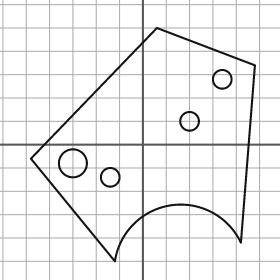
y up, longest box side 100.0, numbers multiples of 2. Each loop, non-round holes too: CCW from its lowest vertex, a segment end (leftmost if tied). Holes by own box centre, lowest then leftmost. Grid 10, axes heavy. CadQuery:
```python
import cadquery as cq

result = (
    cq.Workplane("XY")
    .moveTo(-12.0, -50.0)
    .threePointArc((12.0, -26.0), (42.0, -42.0))
    .lineTo(48.0, 34.0)
    .lineTo(6.0, 50.0)
    .lineTo(-48.0, -6.0)
    .close()
    .moveTo(-14.0, -14.0)
    .circle(4.0)
    .moveTo(-30.0, -8.0)
    .circle(6.0)
    .moveTo(20.0, 10.0)
    .circle(4.0)
    .moveTo(34.0, 28.0)
    .circle(4.0)
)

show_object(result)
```